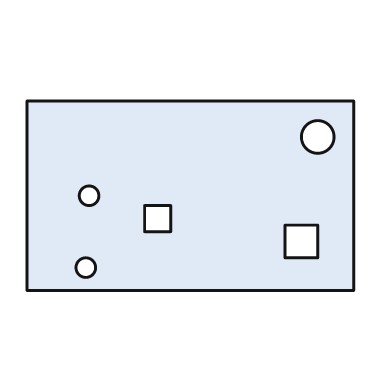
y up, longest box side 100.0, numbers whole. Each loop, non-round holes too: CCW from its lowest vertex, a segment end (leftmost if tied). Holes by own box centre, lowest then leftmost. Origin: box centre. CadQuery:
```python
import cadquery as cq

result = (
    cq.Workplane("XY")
    .moveTo(-50.0, -29.0)
    .lineTo(50.0, -29.0)
    .lineTo(50.0, 29.0)
    .lineTo(-50.0, 29.0)
    .close()
    .moveTo(-32.0, -22.0)
    .circle(3.0)
    .moveTo(29.0, -19.0)
    .lineTo(39.0, -19.0)
    .lineTo(39.0, -9.0)
    .lineTo(29.0, -9.0)
    .close()
    .moveTo(-14.0, -11.0)
    .lineTo(-6.0, -11.0)
    .lineTo(-6.0, -3.0)
    .lineTo(-14.0, -3.0)
    .close()
    .moveTo(-31.0, 0.0)
    .circle(3.0)
    .moveTo(39.0, 18.0)
    .circle(5.0)
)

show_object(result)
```